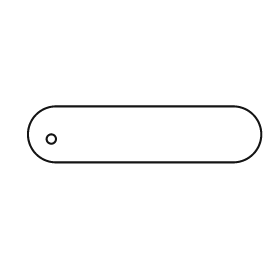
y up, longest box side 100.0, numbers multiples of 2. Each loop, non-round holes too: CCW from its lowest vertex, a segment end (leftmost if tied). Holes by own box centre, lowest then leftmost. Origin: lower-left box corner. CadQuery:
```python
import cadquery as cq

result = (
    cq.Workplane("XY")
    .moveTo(12.0, 0.0)
    .lineTo(88.0, 0.0)
    .threePointArc((100.0, 12.0), (88.0, 24.0))
    .lineTo(12.0, 24.0)
    .threePointArc((0.0, 12.0), (12.0, 0.0))
    .close()
    .moveTo(10.0, 10.0)
    .circle(2.0)
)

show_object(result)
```